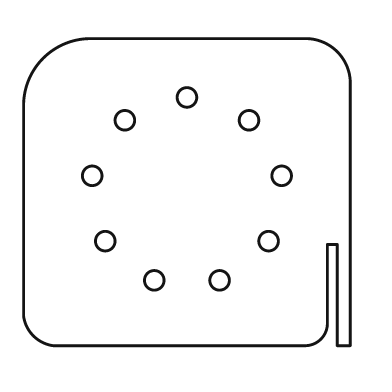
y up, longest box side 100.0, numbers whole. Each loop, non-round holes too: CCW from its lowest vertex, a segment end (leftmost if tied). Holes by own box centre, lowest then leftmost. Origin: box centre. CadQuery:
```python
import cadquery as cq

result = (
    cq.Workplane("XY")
    .moveTo(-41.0, -47.0)
    .lineTo(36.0, -47.0)
    .threePointArc((41.0, -45.0), (43.0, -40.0))
    .lineTo(43.0, -16.0)
    .lineTo(46.0, -16.0)
    .lineTo(46.0, -47.0)
    .lineTo(50.0, -47.0)
    .lineTo(50.0, 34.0)
    .threePointArc((46.0, 43.0), (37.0, 47.0))
    .lineTo(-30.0, 47.0)
    .threePointArc((-44.0, 41.0), (-50.0, 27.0))
    .lineTo(-50.0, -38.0)
    .threePointArc((-47.0, -44.0), (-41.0, -47.0))
    .close()
    .moveTo(-10.0, -27.0)
    .circle(3.0)
    .moveTo(10.0, -27.0)
    .circle(3.0)
    .moveTo(-25.0, -15.0)
    .circle(3.0)
    .moveTo(25.0, -15.0)
    .circle(3.0)
    .moveTo(-29.0, 5.0)
    .circle(3.0)
    .moveTo(29.0, 5.0)
    .circle(3.0)
    .moveTo(-19.0, 22.0)
    .circle(3.0)
    .moveTo(19.0, 22.0)
    .circle(3.0)
    .moveTo(0.0, 29.0)
    .circle(3.0)
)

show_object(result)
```